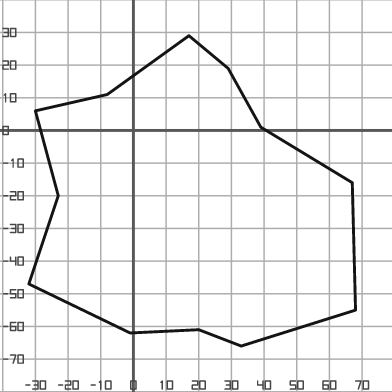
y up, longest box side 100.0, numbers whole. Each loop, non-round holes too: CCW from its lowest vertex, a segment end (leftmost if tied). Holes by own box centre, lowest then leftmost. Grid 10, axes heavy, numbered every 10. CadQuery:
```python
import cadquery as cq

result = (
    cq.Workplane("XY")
    .moveTo(33.0, -66.0)
    .lineTo(68.0, -55.0)
    .lineTo(67.0, -16.0)
    .lineTo(39.0, 1.0)
    .lineTo(29.0, 19.0)
    .lineTo(17.0, 29.0)
    .lineTo(-8.0, 11.0)
    .lineTo(-30.0, 6.0)
    .lineTo(-23.0, -20.0)
    .lineTo(-32.0, -47.0)
    .lineTo(-1.0, -62.0)
    .lineTo(20.0, -61.0)
    .close()
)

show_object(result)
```